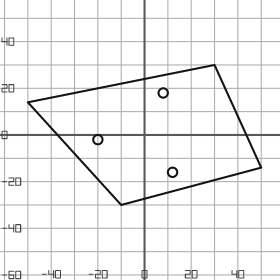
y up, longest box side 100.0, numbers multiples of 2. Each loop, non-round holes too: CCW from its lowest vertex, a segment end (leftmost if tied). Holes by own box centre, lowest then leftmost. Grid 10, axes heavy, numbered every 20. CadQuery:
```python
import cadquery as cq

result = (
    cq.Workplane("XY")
    .moveTo(-10.0, -30.0)
    .lineTo(50.0, -14.0)
    .lineTo(30.0, 30.0)
    .lineTo(-50.0, 14.0)
    .close()
    .moveTo(12.0, -16.0)
    .circle(2.0)
    .moveTo(-20.0, -2.0)
    .circle(2.0)
    .moveTo(8.0, 18.0)
    .circle(2.0)
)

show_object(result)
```